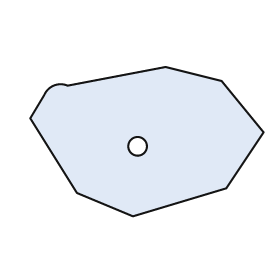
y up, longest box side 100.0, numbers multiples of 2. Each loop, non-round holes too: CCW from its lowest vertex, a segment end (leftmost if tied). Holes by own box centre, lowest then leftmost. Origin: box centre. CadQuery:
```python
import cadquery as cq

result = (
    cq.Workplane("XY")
    .moveTo(-6.0, -32.0)
    .lineTo(34.0, -20.0)
    .lineTo(50.0, 4.0)
    .lineTo(32.0, 26.0)
    .lineTo(8.0, 32.0)
    .lineTo(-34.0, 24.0)
    .threePointArc((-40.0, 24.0), (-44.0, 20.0))
    .lineTo(-50.0, 10.0)
    .lineTo(-30.0, -22.0)
    .close()
    .moveTo(-4.0, -2.0)
    .circle(4.0)
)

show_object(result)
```